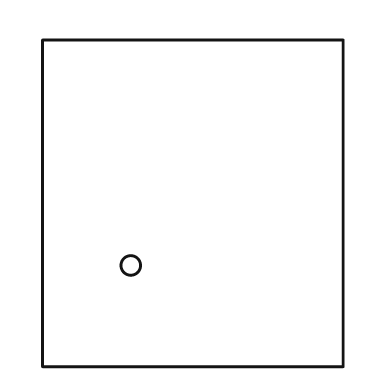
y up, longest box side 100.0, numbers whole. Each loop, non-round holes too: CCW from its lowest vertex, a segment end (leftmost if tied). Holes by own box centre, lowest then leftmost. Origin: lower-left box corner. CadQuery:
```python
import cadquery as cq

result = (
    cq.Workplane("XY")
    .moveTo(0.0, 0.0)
    .lineTo(92.0, 0.0)
    .lineTo(92.0, 100.0)
    .lineTo(0.0, 100.0)
    .close()
    .moveTo(27.0, 31.0)
    .circle(3.0)
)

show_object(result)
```